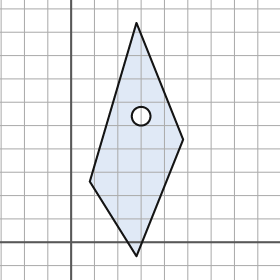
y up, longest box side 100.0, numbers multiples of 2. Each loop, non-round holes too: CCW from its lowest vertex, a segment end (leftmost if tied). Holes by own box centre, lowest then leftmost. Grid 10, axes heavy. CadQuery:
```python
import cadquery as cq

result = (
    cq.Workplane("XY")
    .moveTo(28.0, -6.0)
    .lineTo(48.0, 44.0)
    .lineTo(28.0, 94.0)
    .lineTo(8.0, 26.0)
    .close()
    .moveTo(30.0, 54.0)
    .circle(4.0)
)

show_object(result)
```